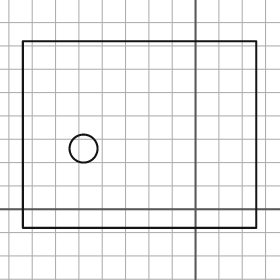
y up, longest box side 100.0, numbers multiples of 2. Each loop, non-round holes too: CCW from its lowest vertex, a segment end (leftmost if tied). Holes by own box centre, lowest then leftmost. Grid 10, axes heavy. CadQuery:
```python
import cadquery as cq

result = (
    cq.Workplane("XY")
    .moveTo(-74.0, -8.0)
    .lineTo(26.0, -8.0)
    .lineTo(26.0, 72.0)
    .lineTo(-74.0, 72.0)
    .close()
    .moveTo(-48.0, 26.0)
    .circle(6.0)
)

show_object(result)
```